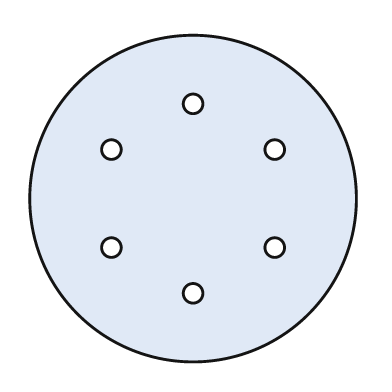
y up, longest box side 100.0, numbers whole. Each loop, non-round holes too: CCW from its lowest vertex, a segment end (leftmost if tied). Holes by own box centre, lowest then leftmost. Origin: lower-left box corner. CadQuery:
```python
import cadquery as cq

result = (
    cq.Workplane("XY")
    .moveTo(50.0, 50.0)
    .circle(50.0)
    .moveTo(50.0, 21.0)
    .circle(3.0)
    .moveTo(25.0, 35.0)
    .circle(3.0)
    .moveTo(75.0, 35.0)
    .circle(3.0)
    .moveTo(25.0, 65.0)
    .circle(3.0)
    .moveTo(75.0, 65.0)
    .circle(3.0)
    .moveTo(50.0, 79.0)
    .circle(3.0)
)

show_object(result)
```